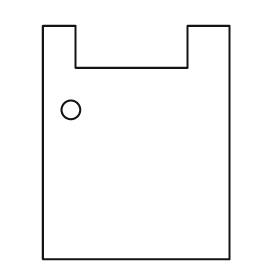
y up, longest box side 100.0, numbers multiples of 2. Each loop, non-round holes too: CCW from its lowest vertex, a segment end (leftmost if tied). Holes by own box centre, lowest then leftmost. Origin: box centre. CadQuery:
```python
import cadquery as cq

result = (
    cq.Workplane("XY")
    .moveTo(-40.0, -50.0)
    .lineTo(40.0, -50.0)
    .lineTo(40.0, 50.0)
    .lineTo(22.0, 50.0)
    .lineTo(22.0, 32.0)
    .lineTo(-26.0, 32.0)
    .lineTo(-26.0, 50.0)
    .lineTo(-40.0, 50.0)
    .close()
    .moveTo(-28.0, 14.0)
    .circle(4.0)
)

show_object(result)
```